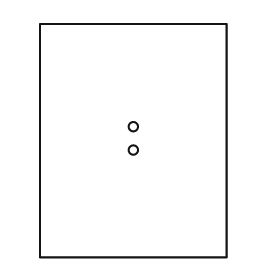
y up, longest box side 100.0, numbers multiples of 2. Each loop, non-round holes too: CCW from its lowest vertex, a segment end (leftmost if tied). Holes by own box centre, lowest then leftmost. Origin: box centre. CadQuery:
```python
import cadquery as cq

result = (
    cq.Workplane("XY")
    .moveTo(-40.0, -50.0)
    .lineTo(40.0, -50.0)
    .lineTo(40.0, 50.0)
    .lineTo(-40.0, 50.0)
    .close()
    .moveTo(0.0, -4.0)
    .circle(2.0)
    .moveTo(0.0, 6.0)
    .circle(2.0)
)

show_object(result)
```